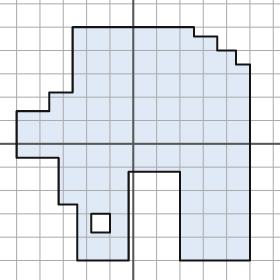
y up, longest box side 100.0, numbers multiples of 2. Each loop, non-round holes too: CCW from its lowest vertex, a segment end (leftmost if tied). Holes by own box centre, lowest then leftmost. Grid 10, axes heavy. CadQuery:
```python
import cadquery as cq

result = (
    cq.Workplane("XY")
    .moveTo(-24.0, -50.0)
    .lineTo(-2.0, -50.0)
    .lineTo(-2.0, -12.0)
    .lineTo(20.0, -12.0)
    .lineTo(20.0, -50.0)
    .lineTo(50.0, -50.0)
    .lineTo(50.0, 34.0)
    .lineTo(44.0, 34.0)
    .lineTo(44.0, 40.0)
    .lineTo(36.0, 40.0)
    .lineTo(36.0, 46.0)
    .lineTo(26.0, 46.0)
    .lineTo(26.0, 50.0)
    .lineTo(-26.0, 50.0)
    .lineTo(-26.0, 22.0)
    .lineTo(-36.0, 22.0)
    .lineTo(-36.0, 14.0)
    .lineTo(-50.0, 14.0)
    .lineTo(-50.0, -6.0)
    .lineTo(-32.0, -6.0)
    .lineTo(-32.0, -26.0)
    .lineTo(-24.0, -26.0)
    .close()
    .moveTo(-18.0, -38.0)
    .lineTo(-10.0, -38.0)
    .lineTo(-10.0, -30.0)
    .lineTo(-18.0, -30.0)
    .close()
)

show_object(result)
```